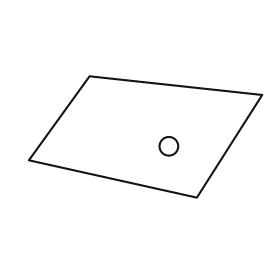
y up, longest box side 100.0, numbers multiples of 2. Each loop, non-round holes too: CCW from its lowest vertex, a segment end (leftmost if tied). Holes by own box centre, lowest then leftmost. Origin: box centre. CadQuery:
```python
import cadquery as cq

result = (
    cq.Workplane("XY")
    .moveTo(22.0, -26.0)
    .lineTo(50.0, 18.0)
    .lineTo(-24.0, 26.0)
    .lineTo(-50.0, -10.0)
    .close()
    .moveTo(10.0, -4.0)
    .circle(4.0)
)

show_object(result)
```